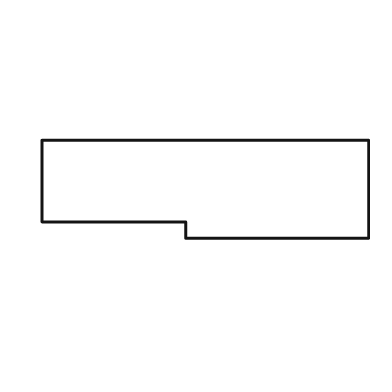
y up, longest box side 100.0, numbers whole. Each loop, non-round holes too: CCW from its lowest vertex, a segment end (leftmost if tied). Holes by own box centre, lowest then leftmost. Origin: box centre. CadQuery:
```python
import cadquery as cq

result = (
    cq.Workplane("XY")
    .moveTo(-6.0, -15.0)
    .lineTo(50.0, -15.0)
    .lineTo(50.0, 15.0)
    .lineTo(-50.0, 15.0)
    .lineTo(-50.0, -10.0)
    .lineTo(-6.0, -10.0)
    .close()
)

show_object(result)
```